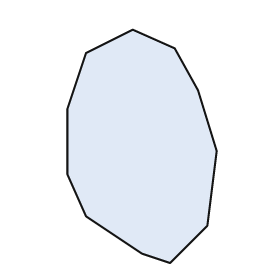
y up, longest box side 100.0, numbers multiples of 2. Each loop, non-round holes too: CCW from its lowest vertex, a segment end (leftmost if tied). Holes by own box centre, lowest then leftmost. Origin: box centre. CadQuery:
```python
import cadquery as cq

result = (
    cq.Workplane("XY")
    .moveTo(12.0, -50.0)
    .lineTo(28.0, -34.0)
    .lineTo(32.0, -2.0)
    .lineTo(24.0, 24.0)
    .lineTo(14.0, 42.0)
    .lineTo(-4.0, 50.0)
    .lineTo(-24.0, 40.0)
    .lineTo(-32.0, 16.0)
    .lineTo(-32.0, -12.0)
    .lineTo(-24.0, -30.0)
    .lineTo(0.0, -46.0)
    .close()
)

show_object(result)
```